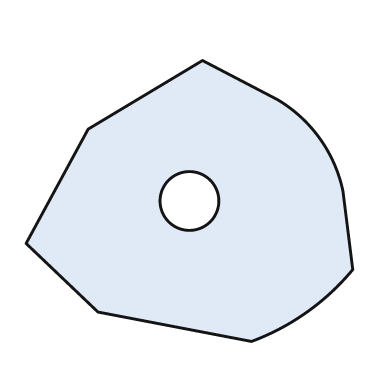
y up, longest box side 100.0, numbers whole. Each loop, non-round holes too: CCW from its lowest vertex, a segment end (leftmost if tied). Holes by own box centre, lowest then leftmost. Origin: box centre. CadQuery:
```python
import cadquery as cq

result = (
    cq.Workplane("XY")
    .moveTo(19.0, -43.0)
    .threePointArc((36.0, -34.0), (50.0, -21.0))
    .lineTo(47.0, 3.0)
    .threePointArc((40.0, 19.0), (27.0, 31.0))
    .lineTo(4.0, 43.0)
    .lineTo(-31.0, 22.0)
    .lineTo(-50.0, -13.0)
    .lineTo(-28.0, -34.0)
    .close()
    .moveTo(0.0, 0.0)
    .circle(9.0)
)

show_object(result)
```